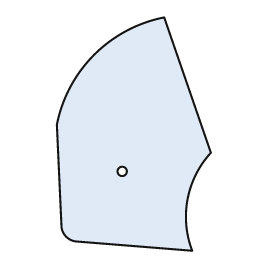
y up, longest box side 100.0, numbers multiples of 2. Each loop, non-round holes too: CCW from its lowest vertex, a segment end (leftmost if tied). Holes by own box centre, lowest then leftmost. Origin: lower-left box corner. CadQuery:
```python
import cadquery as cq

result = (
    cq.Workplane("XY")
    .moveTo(58.0, 0.0)
    .threePointArc((56.0, 22.0), (66.0, 42.0))
    .lineTo(46.0, 100.0)
    .threePointArc((16.0, 84.0), (0.0, 54.0))
    .lineTo(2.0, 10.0)
    .threePointArc((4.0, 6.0), (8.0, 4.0))
    .close()
    .moveTo(28.0, 34.0)
    .circle(2.0)
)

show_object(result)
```